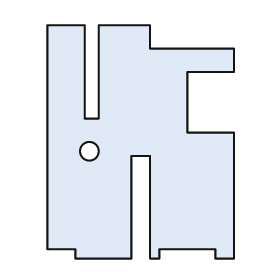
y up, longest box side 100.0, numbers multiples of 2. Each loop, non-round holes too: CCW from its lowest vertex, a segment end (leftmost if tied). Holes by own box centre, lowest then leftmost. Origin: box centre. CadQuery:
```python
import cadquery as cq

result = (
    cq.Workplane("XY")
    .moveTo(-28.0, -50.0)
    .lineTo(-4.0, -50.0)
    .lineTo(-4.0, -6.0)
    .lineTo(4.0, -6.0)
    .lineTo(4.0, -50.0)
    .lineTo(8.0, -50.0)
    .lineTo(8.0, -46.0)
    .lineTo(32.0, -46.0)
    .lineTo(32.0, -50.0)
    .lineTo(40.0, -50.0)
    .lineTo(40.0, 4.0)
    .lineTo(20.0, 4.0)
    .lineTo(20.0, 30.0)
    .lineTo(40.0, 30.0)
    .lineTo(40.0, 40.0)
    .lineTo(4.0, 40.0)
    .lineTo(4.0, 50.0)
    .lineTo(-18.0, 50.0)
    .lineTo(-18.0, 10.0)
    .lineTo(-24.0, 10.0)
    .lineTo(-24.0, 50.0)
    .lineTo(-40.0, 50.0)
    .lineTo(-40.0, -46.0)
    .lineTo(-28.0, -46.0)
    .close()
    .moveTo(-22.0, -4.0)
    .circle(4.0)
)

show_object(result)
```